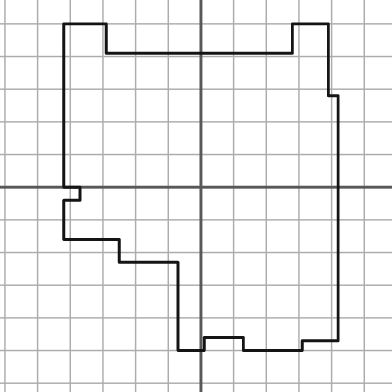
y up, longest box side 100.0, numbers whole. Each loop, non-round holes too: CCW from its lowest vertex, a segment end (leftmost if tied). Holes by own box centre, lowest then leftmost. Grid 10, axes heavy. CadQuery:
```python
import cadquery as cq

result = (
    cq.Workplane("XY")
    .moveTo(-7.0, -50.0)
    .lineTo(1.0, -50.0)
    .lineTo(1.0, -46.0)
    .lineTo(13.0, -46.0)
    .lineTo(13.0, -50.0)
    .lineTo(31.0, -50.0)
    .lineTo(31.0, -47.0)
    .lineTo(42.0, -47.0)
    .lineTo(42.0, 28.0)
    .lineTo(39.0, 28.0)
    .lineTo(39.0, 50.0)
    .lineTo(28.0, 50.0)
    .lineTo(28.0, 41.0)
    .lineTo(-29.0, 41.0)
    .lineTo(-29.0, 50.0)
    .lineTo(-42.0, 50.0)
    .lineTo(-42.0, 0.0)
    .lineTo(-37.0, 0.0)
    .lineTo(-37.0, -4.0)
    .lineTo(-42.0, -4.0)
    .lineTo(-42.0, -16.0)
    .lineTo(-25.0, -16.0)
    .lineTo(-25.0, -23.0)
    .lineTo(-7.0, -23.0)
    .close()
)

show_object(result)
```